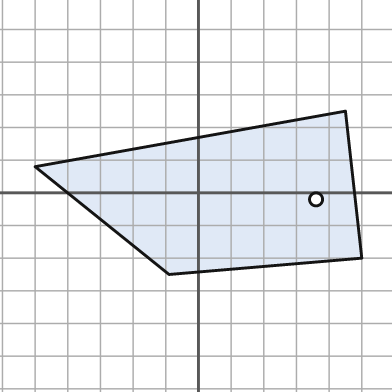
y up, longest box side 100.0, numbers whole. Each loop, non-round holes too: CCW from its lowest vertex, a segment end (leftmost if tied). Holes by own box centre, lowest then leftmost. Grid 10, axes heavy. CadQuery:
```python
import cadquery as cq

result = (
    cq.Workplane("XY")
    .moveTo(-9.0, -25.0)
    .lineTo(50.0, -20.0)
    .lineTo(45.0, 25.0)
    .lineTo(-50.0, 8.0)
    .close()
    .moveTo(36.0, -2.0)
    .circle(2.0)
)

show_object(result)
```